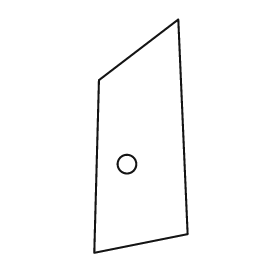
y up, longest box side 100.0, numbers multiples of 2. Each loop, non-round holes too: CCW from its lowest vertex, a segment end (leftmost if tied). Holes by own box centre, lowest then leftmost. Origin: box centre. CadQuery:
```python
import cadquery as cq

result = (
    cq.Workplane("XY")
    .moveTo(-20.0, -50.0)
    .lineTo(20.0, -42.0)
    .lineTo(16.0, 50.0)
    .lineTo(-18.0, 24.0)
    .close()
    .moveTo(-6.0, -12.0)
    .circle(4.0)
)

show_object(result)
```